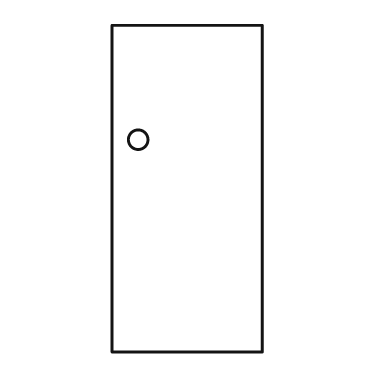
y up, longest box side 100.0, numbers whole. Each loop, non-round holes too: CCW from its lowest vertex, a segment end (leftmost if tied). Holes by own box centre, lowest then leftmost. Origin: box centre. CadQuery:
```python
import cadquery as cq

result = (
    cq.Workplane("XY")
    .moveTo(-23.0, -50.0)
    .lineTo(23.0, -50.0)
    .lineTo(23.0, 50.0)
    .lineTo(-23.0, 50.0)
    .close()
    .moveTo(-15.0, 15.0)
    .circle(3.0)
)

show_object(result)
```